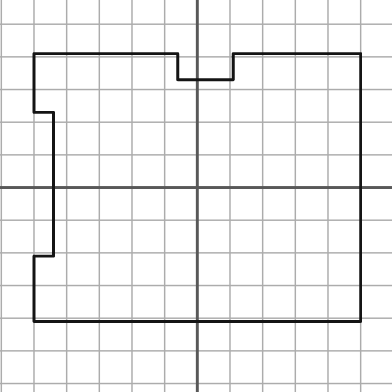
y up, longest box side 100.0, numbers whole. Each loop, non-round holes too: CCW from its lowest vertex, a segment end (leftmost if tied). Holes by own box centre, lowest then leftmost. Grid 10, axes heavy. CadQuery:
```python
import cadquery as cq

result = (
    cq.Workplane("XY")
    .moveTo(-50.0, -41.0)
    .lineTo(50.0, -41.0)
    .lineTo(50.0, 41.0)
    .lineTo(11.0, 41.0)
    .lineTo(11.0, 33.0)
    .lineTo(-6.0, 33.0)
    .lineTo(-6.0, 41.0)
    .lineTo(-50.0, 41.0)
    .lineTo(-50.0, 23.0)
    .lineTo(-44.0, 23.0)
    .lineTo(-44.0, -21.0)
    .lineTo(-50.0, -21.0)
    .close()
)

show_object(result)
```